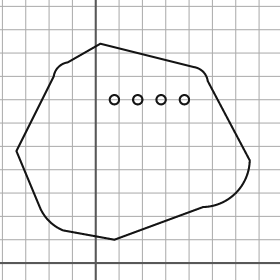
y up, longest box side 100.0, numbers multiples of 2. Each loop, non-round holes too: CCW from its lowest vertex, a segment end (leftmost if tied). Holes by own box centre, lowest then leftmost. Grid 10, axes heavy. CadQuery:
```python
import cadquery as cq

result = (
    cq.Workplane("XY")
    .moveTo(8.0, 10.0)
    .lineTo(46.0, 24.0)
    .threePointArc((60.0, 30.0), (66.0, 44.0))
    .lineTo(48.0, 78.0)
    .threePointArc((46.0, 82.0), (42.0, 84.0))
    .lineTo(2.0, 94.0)
    .lineTo(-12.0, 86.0)
    .threePointArc((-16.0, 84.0), (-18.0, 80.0))
    .lineTo(-34.0, 48.0)
    .lineTo(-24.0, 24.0)
    .threePointArc((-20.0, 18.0), (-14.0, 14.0))
    .close()
    .moveTo(8.0, 70.0)
    .circle(2.0)
    .moveTo(18.0, 70.0)
    .circle(2.0)
    .moveTo(28.0, 70.0)
    .circle(2.0)
    .moveTo(38.0, 70.0)
    .circle(2.0)
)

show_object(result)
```